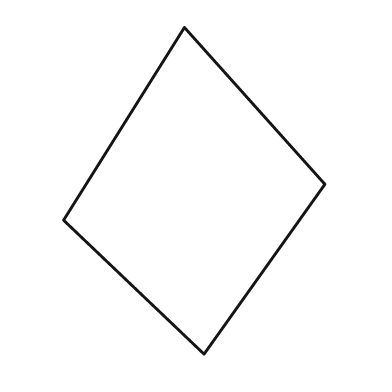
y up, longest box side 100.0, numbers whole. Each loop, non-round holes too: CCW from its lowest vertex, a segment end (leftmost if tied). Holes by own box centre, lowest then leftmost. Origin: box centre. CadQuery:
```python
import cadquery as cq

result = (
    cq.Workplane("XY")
    .moveTo(3.0, -50.0)
    .lineTo(40.0, 2.0)
    .lineTo(-3.0, 50.0)
    .lineTo(-40.0, -9.0)
    .close()
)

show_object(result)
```